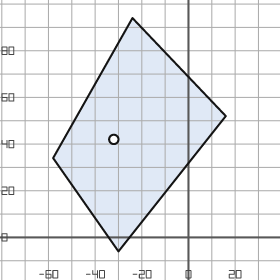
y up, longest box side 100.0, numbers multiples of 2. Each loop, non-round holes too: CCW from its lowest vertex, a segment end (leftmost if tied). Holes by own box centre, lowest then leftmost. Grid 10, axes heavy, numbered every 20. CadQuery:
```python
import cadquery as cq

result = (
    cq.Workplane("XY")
    .moveTo(-30.0, -6.0)
    .lineTo(16.0, 52.0)
    .lineTo(-24.0, 94.0)
    .lineTo(-58.0, 34.0)
    .close()
    .moveTo(-32.0, 42.0)
    .circle(2.0)
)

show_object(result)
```